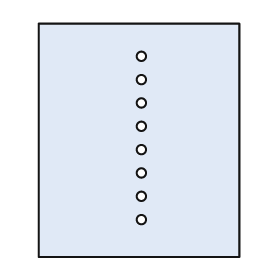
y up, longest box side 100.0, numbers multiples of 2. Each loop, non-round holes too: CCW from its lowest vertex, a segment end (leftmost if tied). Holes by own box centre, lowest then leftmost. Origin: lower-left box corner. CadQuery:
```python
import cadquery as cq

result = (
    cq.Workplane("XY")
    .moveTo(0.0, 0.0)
    .lineTo(86.0, 0.0)
    .lineTo(86.0, 100.0)
    .lineTo(0.0, 100.0)
    .close()
    .moveTo(44.0, 16.0)
    .circle(2.0)
    .moveTo(44.0, 26.0)
    .circle(2.0)
    .moveTo(44.0, 36.0)
    .circle(2.0)
    .moveTo(44.0, 46.0)
    .circle(2.0)
    .moveTo(44.0, 56.0)
    .circle(2.0)
    .moveTo(44.0, 66.0)
    .circle(2.0)
    .moveTo(44.0, 76.0)
    .circle(2.0)
    .moveTo(44.0, 86.0)
    .circle(2.0)
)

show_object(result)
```